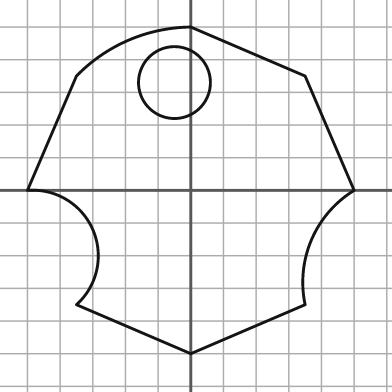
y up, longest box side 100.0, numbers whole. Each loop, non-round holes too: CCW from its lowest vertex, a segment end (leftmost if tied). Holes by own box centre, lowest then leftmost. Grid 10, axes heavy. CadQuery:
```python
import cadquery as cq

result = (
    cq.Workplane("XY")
    .moveTo(0.0, -50.0)
    .lineTo(35.0, -35.0)
    .threePointArc((37.0, -15.0), (50.0, 0.0))
    .lineTo(35.0, 35.0)
    .lineTo(0.0, 50.0)
    .threePointArc((-19.0, 46.0), (-35.0, 35.0))
    .lineTo(-50.0, 0.0)
    .threePointArc((-30.0, -12.0), (-35.0, -35.0))
    .close()
    .moveTo(-5.0, 33.0)
    .circle(11.0)
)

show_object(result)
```